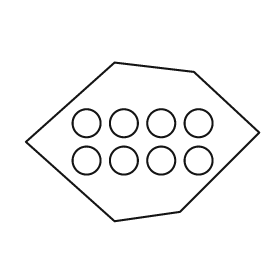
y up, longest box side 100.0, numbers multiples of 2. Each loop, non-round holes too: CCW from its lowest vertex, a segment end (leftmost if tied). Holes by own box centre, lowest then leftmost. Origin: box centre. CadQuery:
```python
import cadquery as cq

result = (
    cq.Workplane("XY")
    .moveTo(-12.0, -34.0)
    .lineTo(16.0, -30.0)
    .lineTo(50.0, 4.0)
    .lineTo(22.0, 30.0)
    .lineTo(-12.0, 34.0)
    .lineTo(-50.0, 0.0)
    .close()
    .moveTo(-24.0, -8.0)
    .circle(6.0)
    .moveTo(-8.0, -8.0)
    .circle(6.0)
    .moveTo(8.0, -8.0)
    .circle(6.0)
    .moveTo(24.0, -8.0)
    .circle(6.0)
    .moveTo(-24.0, 8.0)
    .circle(6.0)
    .moveTo(-8.0, 8.0)
    .circle(6.0)
    .moveTo(8.0, 8.0)
    .circle(6.0)
    .moveTo(24.0, 8.0)
    .circle(6.0)
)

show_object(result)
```